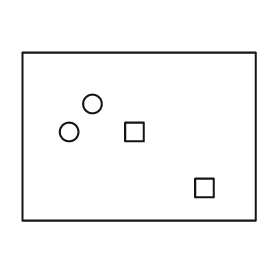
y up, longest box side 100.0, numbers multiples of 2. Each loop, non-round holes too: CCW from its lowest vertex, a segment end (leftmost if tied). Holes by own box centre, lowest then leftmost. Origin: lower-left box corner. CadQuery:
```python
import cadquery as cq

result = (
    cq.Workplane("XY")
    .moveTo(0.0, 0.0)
    .lineTo(100.0, 0.0)
    .lineTo(100.0, 72.0)
    .lineTo(0.0, 72.0)
    .close()
    .moveTo(74.0, 10.0)
    .lineTo(82.0, 10.0)
    .lineTo(82.0, 18.0)
    .lineTo(74.0, 18.0)
    .close()
    .moveTo(20.0, 38.0)
    .circle(4.0)
    .moveTo(44.0, 34.0)
    .lineTo(52.0, 34.0)
    .lineTo(52.0, 42.0)
    .lineTo(44.0, 42.0)
    .close()
    .moveTo(30.0, 50.0)
    .circle(4.0)
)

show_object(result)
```